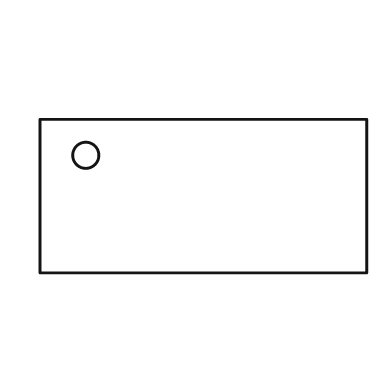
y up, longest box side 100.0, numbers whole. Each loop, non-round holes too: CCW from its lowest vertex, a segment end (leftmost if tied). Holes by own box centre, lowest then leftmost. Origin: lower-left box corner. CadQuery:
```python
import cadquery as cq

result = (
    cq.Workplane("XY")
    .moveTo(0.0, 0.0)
    .lineTo(100.0, 0.0)
    .lineTo(100.0, 47.0)
    .lineTo(0.0, 47.0)
    .close()
    .moveTo(14.0, 36.0)
    .circle(4.0)
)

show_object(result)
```